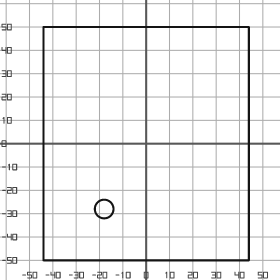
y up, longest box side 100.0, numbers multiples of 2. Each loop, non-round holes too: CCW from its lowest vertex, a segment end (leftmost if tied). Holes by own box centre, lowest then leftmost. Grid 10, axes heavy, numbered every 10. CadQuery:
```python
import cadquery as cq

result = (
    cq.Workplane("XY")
    .moveTo(-44.0, -50.0)
    .lineTo(44.0, -50.0)
    .lineTo(44.0, 50.0)
    .lineTo(-44.0, 50.0)
    .close()
    .moveTo(-18.0, -28.0)
    .circle(4.0)
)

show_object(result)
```